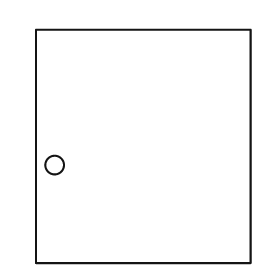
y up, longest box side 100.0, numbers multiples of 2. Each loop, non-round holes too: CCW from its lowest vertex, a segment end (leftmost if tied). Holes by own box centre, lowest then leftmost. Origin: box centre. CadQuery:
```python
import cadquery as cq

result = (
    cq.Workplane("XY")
    .moveTo(-46.0, -50.0)
    .lineTo(46.0, -50.0)
    .lineTo(46.0, 50.0)
    .lineTo(-46.0, 50.0)
    .close()
    .moveTo(-38.0, -8.0)
    .circle(4.0)
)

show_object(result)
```